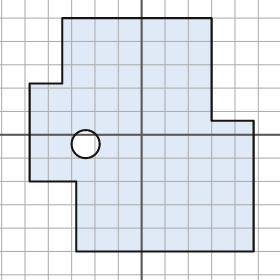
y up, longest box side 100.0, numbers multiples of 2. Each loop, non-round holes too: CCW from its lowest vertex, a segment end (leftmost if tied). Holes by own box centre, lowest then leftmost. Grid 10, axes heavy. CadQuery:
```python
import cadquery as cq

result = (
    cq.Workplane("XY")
    .moveTo(-28.0, -50.0)
    .lineTo(48.0, -50.0)
    .lineTo(48.0, 6.0)
    .lineTo(30.0, 6.0)
    .lineTo(30.0, 50.0)
    .lineTo(-34.0, 50.0)
    .lineTo(-34.0, 22.0)
    .lineTo(-48.0, 22.0)
    .lineTo(-48.0, -20.0)
    .lineTo(-28.0, -20.0)
    .close()
    .moveTo(-24.0, -4.0)
    .circle(6.0)
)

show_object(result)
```